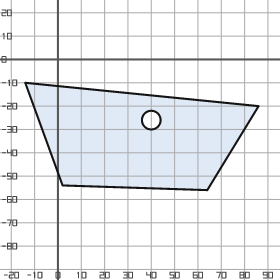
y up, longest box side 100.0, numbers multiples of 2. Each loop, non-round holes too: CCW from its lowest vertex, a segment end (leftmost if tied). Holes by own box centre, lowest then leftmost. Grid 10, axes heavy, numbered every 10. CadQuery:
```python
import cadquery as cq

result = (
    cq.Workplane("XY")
    .moveTo(64.0, -56.0)
    .lineTo(86.0, -20.0)
    .lineTo(-14.0, -10.0)
    .lineTo(2.0, -54.0)
    .close()
    .moveTo(40.0, -26.0)
    .circle(4.0)
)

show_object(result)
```